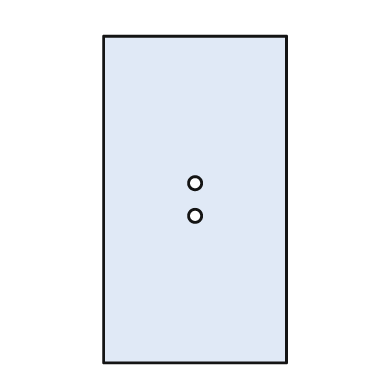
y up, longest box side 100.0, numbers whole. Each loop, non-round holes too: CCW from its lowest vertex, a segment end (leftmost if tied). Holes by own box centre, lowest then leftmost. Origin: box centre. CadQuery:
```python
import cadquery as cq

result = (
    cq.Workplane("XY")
    .moveTo(-28.0, -50.0)
    .lineTo(28.0, -50.0)
    .lineTo(28.0, 50.0)
    .lineTo(-28.0, 50.0)
    .close()
    .moveTo(0.0, -5.0)
    .circle(2.0)
    .moveTo(0.0, 5.0)
    .circle(2.0)
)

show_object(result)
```